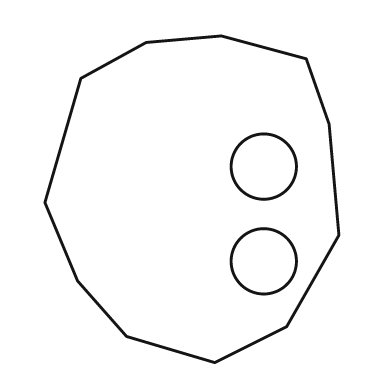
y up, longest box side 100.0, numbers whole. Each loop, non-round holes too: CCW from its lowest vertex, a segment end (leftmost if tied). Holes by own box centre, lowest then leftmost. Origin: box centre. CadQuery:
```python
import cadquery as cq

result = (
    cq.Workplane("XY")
    .moveTo(7.0, -50.0)
    .lineTo(29.0, -39.0)
    .lineTo(45.0, -11.0)
    .lineTo(42.0, 23.0)
    .lineTo(35.0, 43.0)
    .lineTo(9.0, 50.0)
    .lineTo(-14.0, 48.0)
    .lineTo(-34.0, 37.0)
    .lineTo(-45.0, -1.0)
    .lineTo(-35.0, -25.0)
    .lineTo(-20.0, -42.0)
    .close()
    .moveTo(22.0, -19.0)
    .circle(10.0)
    .moveTo(22.0, 10.0)
    .circle(10.0)
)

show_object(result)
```